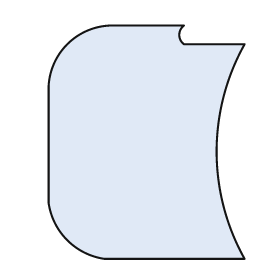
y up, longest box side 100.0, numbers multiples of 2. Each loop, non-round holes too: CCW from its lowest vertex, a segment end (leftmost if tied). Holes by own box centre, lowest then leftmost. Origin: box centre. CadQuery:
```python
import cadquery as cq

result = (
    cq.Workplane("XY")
    .moveTo(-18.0, -50.0)
    .lineTo(42.0, -50.0)
    .threePointArc((30.0, -4.0), (42.0, 42.0))
    .lineTo(16.0, 42.0)
    .threePointArc((14.0, 46.0), (16.0, 50.0))
    .lineTo(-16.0, 50.0)
    .threePointArc((-34.0, 42.0), (-42.0, 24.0))
    .lineTo(-42.0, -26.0)
    .threePointArc((-34.0, -42.0), (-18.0, -50.0))
    .close()
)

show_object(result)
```